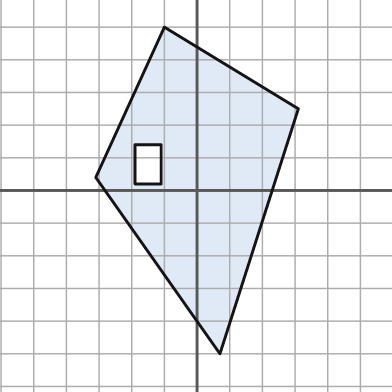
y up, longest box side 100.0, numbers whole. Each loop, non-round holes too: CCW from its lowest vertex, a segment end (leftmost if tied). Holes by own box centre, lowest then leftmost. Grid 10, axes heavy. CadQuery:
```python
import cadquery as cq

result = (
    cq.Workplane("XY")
    .moveTo(7.0, -50.0)
    .lineTo(31.0, 25.0)
    .lineTo(-10.0, 50.0)
    .lineTo(-31.0, 4.0)
    .close()
    .moveTo(-19.0, 2.0)
    .lineTo(-11.0, 2.0)
    .lineTo(-11.0, 14.0)
    .lineTo(-19.0, 14.0)
    .close()
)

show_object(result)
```